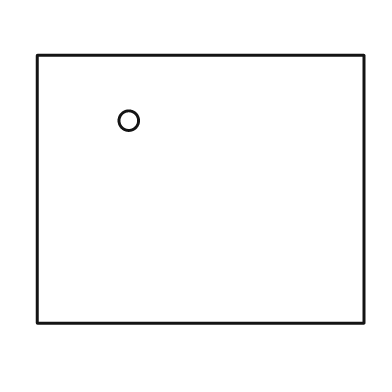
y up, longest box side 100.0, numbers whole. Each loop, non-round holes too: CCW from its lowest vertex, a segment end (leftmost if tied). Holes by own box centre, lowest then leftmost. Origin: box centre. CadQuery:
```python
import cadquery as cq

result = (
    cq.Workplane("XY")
    .moveTo(-50.0, -41.0)
    .lineTo(50.0, -41.0)
    .lineTo(50.0, 41.0)
    .lineTo(-50.0, 41.0)
    .close()
    .moveTo(-22.0, 21.0)
    .circle(3.0)
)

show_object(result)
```